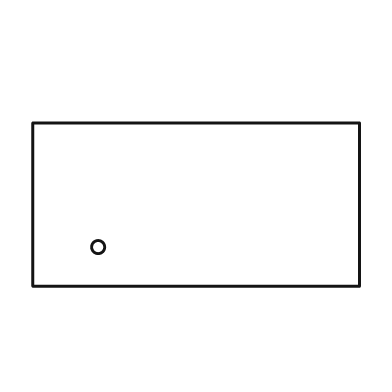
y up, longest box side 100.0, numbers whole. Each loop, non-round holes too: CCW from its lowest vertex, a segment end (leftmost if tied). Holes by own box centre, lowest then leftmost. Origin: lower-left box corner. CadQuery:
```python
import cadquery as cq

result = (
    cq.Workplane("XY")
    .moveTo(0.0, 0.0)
    .lineTo(100.0, 0.0)
    .lineTo(100.0, 50.0)
    .lineTo(0.0, 50.0)
    .close()
    .moveTo(20.0, 12.0)
    .circle(2.0)
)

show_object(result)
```